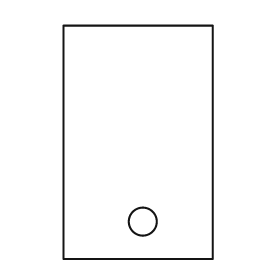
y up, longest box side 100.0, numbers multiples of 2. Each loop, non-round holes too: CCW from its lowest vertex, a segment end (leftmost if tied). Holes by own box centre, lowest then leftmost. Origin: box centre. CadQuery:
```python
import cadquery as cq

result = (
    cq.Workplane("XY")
    .moveTo(-32.0, -50.0)
    .lineTo(32.0, -50.0)
    .lineTo(32.0, 50.0)
    .lineTo(-32.0, 50.0)
    .close()
    .moveTo(2.0, -34.0)
    .circle(6.0)
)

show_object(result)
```